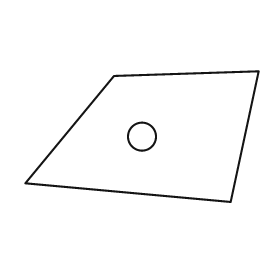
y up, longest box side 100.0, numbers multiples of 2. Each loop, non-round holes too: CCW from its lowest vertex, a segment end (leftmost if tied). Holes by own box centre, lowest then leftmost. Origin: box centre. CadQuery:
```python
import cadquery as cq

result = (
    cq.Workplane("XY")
    .moveTo(38.0, -28.0)
    .lineTo(50.0, 28.0)
    .lineTo(-12.0, 26.0)
    .lineTo(-50.0, -20.0)
    .close()
    .moveTo(0.0, 0.0)
    .circle(6.0)
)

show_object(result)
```